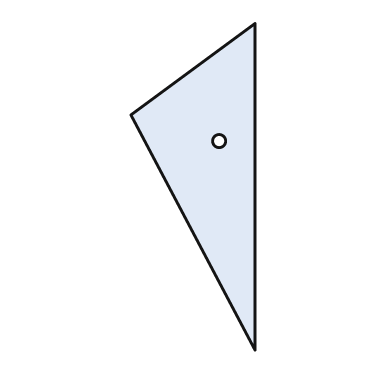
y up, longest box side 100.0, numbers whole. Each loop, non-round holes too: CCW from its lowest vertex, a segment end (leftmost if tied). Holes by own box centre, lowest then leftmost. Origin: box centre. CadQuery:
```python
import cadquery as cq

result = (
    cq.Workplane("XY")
    .moveTo(19.0, -50.0)
    .lineTo(19.0, 50.0)
    .lineTo(-19.0, 22.0)
    .close()
    .moveTo(8.0, 14.0)
    .circle(2.0)
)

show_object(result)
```